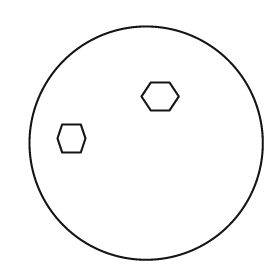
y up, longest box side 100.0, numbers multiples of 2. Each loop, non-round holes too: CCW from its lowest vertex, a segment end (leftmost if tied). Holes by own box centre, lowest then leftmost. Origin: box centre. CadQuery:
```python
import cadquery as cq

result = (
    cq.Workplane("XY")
    .moveTo(0.0, 0.0)
    .circle(50.0)
    .moveTo(-36.0, -4.0)
    .lineTo(-28.0, -4.0)
    .lineTo(-26.0, 2.0)
    .lineTo(-28.0, 8.0)
    .lineTo(-36.0, 8.0)
    .lineTo(-38.0, 2.0)
    .close()
    .moveTo(2.0, 14.0)
    .lineTo(10.0, 14.0)
    .lineTo(14.0, 20.0)
    .lineTo(10.0, 26.0)
    .lineTo(2.0, 26.0)
    .lineTo(-2.0, 20.0)
    .close()
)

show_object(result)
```